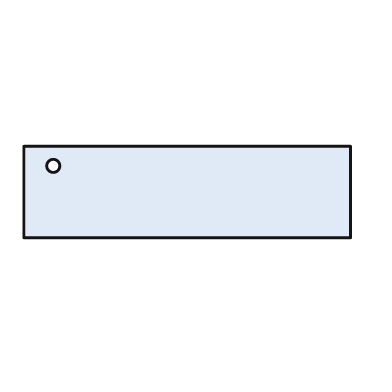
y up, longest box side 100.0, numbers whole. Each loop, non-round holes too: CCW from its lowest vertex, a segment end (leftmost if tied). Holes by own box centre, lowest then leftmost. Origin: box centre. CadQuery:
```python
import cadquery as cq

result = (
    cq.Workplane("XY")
    .moveTo(-50.0, -14.0)
    .lineTo(50.0, -14.0)
    .lineTo(50.0, 14.0)
    .lineTo(-50.0, 14.0)
    .close()
    .moveTo(-41.0, 8.0)
    .circle(2.0)
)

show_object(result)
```